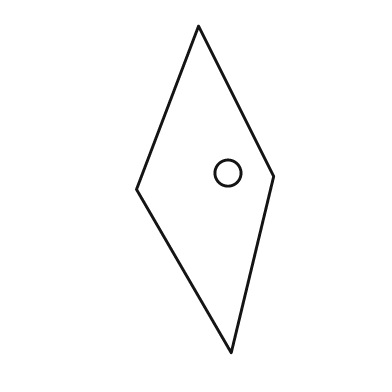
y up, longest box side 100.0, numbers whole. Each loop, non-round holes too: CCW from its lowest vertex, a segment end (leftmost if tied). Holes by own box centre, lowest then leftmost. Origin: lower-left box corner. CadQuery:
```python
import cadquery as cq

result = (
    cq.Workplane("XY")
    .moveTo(29.0, 0.0)
    .lineTo(42.0, 54.0)
    .lineTo(19.0, 100.0)
    .lineTo(0.0, 50.0)
    .close()
    .moveTo(28.0, 55.0)
    .circle(4.0)
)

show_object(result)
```